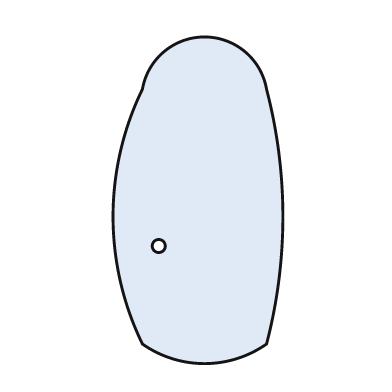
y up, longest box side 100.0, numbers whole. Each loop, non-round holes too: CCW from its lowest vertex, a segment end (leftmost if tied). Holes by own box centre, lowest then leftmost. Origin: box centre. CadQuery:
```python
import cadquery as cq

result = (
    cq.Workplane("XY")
    .moveTo(-17.0, -44.0)
    .threePointArc((2.0, -50.0), (21.0, -44.0))
    .threePointArc((26.0, -5.0), (21.0, 34.0))
    .threePointArc((2.0, 50.0), (-17.0, 34.0))
    .threePointArc((-26.0, -5.0), (-17.0, -44.0))
    .close()
    .moveTo(-12.0, -14.0)
    .circle(2.0)
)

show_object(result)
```